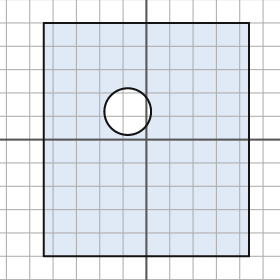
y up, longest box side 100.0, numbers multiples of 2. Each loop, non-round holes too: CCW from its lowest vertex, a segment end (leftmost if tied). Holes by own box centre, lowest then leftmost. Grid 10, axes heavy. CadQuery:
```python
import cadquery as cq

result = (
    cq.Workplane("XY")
    .moveTo(-44.0, -50.0)
    .lineTo(44.0, -50.0)
    .lineTo(44.0, 50.0)
    .lineTo(-44.0, 50.0)
    .close()
    .moveTo(-8.0, 12.0)
    .circle(10.0)
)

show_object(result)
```